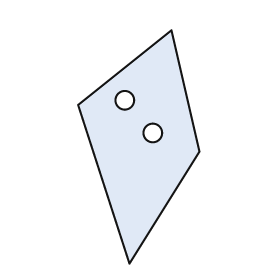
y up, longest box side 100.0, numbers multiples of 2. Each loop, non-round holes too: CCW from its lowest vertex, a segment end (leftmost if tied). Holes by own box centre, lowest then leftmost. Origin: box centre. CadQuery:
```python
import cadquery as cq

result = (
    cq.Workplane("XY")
    .moveTo(-4.0, -50.0)
    .lineTo(26.0, -2.0)
    .lineTo(14.0, 50.0)
    .lineTo(-26.0, 18.0)
    .close()
    .moveTo(6.0, 6.0)
    .circle(4.0)
    .moveTo(-6.0, 20.0)
    .circle(4.0)
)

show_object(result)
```